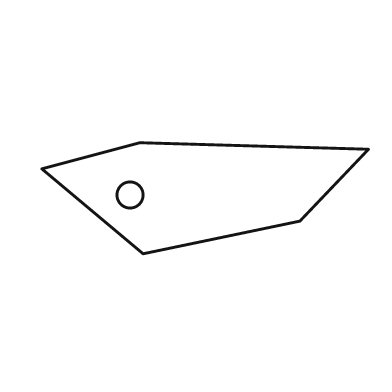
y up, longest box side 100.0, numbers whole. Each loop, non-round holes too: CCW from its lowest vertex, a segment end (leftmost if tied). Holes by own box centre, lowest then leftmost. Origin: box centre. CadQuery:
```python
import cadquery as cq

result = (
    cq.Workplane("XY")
    .moveTo(-19.0, -17.0)
    .lineTo(29.0, -7.0)
    .lineTo(50.0, 15.0)
    .lineTo(-20.0, 17.0)
    .lineTo(-50.0, 9.0)
    .close()
    .moveTo(-23.0, 1.0)
    .circle(4.0)
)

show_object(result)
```